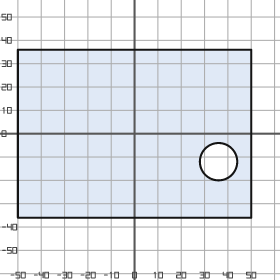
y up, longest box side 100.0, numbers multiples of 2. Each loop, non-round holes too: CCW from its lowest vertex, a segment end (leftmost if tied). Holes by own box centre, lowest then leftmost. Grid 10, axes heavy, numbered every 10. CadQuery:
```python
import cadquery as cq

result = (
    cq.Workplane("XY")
    .moveTo(-50.0, -36.0)
    .lineTo(50.0, -36.0)
    .lineTo(50.0, 36.0)
    .lineTo(-50.0, 36.0)
    .close()
    .moveTo(36.0, -12.0)
    .circle(8.0)
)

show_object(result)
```